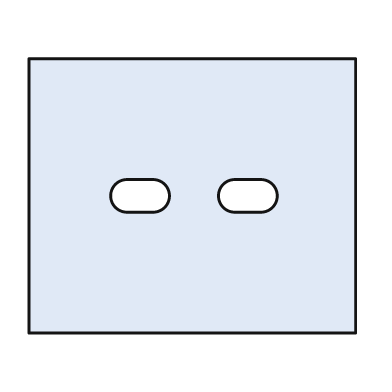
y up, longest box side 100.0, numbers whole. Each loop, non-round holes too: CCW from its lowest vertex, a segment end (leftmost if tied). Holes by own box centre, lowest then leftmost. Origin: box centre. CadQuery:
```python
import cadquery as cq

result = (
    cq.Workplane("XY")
    .moveTo(-50.0, -42.0)
    .lineTo(50.0, -42.0)
    .lineTo(50.0, 42.0)
    .lineTo(-50.0, 42.0)
    .close()
    .moveTo(-20.0, -5.0)
    .lineTo(-12.0, -5.0)
    .threePointArc((-7.0, 0.0), (-12.0, 5.0))
    .lineTo(-20.0, 5.0)
    .threePointArc((-25.0, 0.0), (-20.0, -5.0))
    .close()
    .moveTo(13.0, -5.0)
    .lineTo(21.0, -5.0)
    .threePointArc((26.0, 0.0), (21.0, 5.0))
    .lineTo(13.0, 5.0)
    .threePointArc((8.0, 0.0), (13.0, -5.0))
    .close()
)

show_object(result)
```